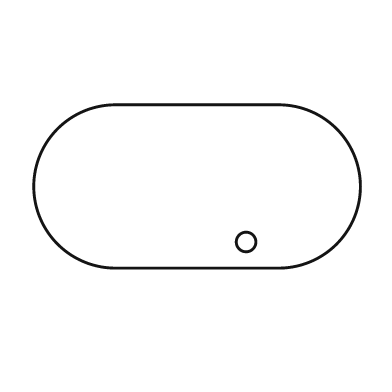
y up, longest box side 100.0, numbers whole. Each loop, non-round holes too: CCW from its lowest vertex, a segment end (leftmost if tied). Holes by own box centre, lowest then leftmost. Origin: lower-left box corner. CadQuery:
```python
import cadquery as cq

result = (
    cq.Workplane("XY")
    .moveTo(25.0, 0.0)
    .lineTo(75.0, 0.0)
    .threePointArc((100.0, 25.0), (75.0, 50.0))
    .lineTo(25.0, 50.0)
    .threePointArc((0.0, 25.0), (25.0, 0.0))
    .close()
    .moveTo(65.0, 8.0)
    .circle(3.0)
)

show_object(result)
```